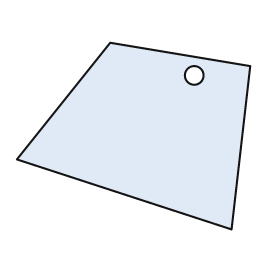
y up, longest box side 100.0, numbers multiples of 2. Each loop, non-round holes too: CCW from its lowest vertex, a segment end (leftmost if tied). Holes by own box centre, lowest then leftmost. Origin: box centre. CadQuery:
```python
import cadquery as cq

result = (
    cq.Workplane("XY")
    .moveTo(42.0, -40.0)
    .lineTo(50.0, 30.0)
    .lineTo(-10.0, 40.0)
    .lineTo(-50.0, -10.0)
    .close()
    .moveTo(26.0, 26.0)
    .circle(4.0)
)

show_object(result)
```